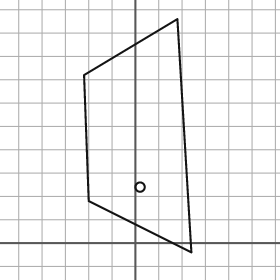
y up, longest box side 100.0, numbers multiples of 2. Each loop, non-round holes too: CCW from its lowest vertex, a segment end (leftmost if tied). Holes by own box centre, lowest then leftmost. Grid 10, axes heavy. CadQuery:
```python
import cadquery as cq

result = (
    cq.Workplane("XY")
    .moveTo(24.0, -4.0)
    .lineTo(18.0, 96.0)
    .lineTo(-22.0, 72.0)
    .lineTo(-20.0, 18.0)
    .close()
    .moveTo(2.0, 24.0)
    .circle(2.0)
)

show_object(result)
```